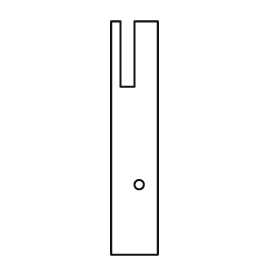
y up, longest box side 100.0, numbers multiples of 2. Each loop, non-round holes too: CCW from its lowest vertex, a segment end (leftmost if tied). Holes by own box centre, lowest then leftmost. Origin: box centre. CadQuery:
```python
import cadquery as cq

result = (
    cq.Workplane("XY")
    .moveTo(-10.0, -50.0)
    .lineTo(10.0, -50.0)
    .lineTo(10.0, 50.0)
    .lineTo(0.0, 50.0)
    .lineTo(0.0, 22.0)
    .lineTo(-6.0, 22.0)
    .lineTo(-6.0, 50.0)
    .lineTo(-10.0, 50.0)
    .close()
    .moveTo(2.0, -20.0)
    .circle(2.0)
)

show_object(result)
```